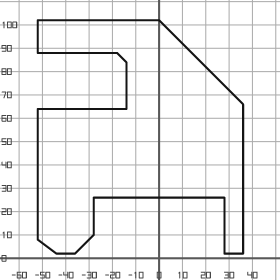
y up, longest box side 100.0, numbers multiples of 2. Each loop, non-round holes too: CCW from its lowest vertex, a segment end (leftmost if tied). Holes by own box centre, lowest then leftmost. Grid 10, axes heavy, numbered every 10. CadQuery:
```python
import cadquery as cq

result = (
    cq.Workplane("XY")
    .moveTo(-44.0, 2.0)
    .lineTo(-36.0, 2.0)
    .lineTo(-28.0, 10.0)
    .lineTo(-28.0, 26.0)
    .lineTo(28.0, 26.0)
    .lineTo(28.0, 2.0)
    .lineTo(36.0, 2.0)
    .lineTo(36.0, 66.0)
    .lineTo(0.0, 102.0)
    .lineTo(-52.0, 102.0)
    .lineTo(-52.0, 88.0)
    .lineTo(-18.0, 88.0)
    .lineTo(-14.0, 84.0)
    .lineTo(-14.0, 64.0)
    .lineTo(-52.0, 64.0)
    .lineTo(-52.0, 8.0)
    .close()
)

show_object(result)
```